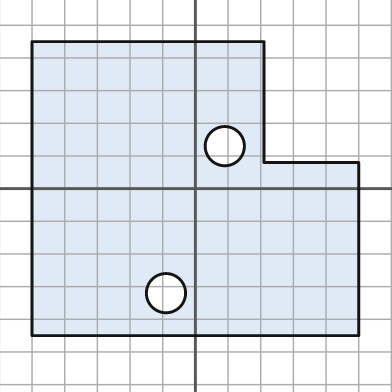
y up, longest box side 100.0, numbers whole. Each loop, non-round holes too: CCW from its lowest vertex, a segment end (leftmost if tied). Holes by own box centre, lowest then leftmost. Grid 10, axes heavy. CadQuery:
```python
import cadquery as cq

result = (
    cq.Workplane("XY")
    .moveTo(-50.0, -45.0)
    .lineTo(50.0, -45.0)
    .lineTo(50.0, 8.0)
    .lineTo(21.0, 8.0)
    .lineTo(21.0, 45.0)
    .lineTo(-50.0, 45.0)
    .close()
    .moveTo(-9.0, -32.0)
    .circle(6.0)
    .moveTo(9.0, 13.0)
    .circle(6.0)
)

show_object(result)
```